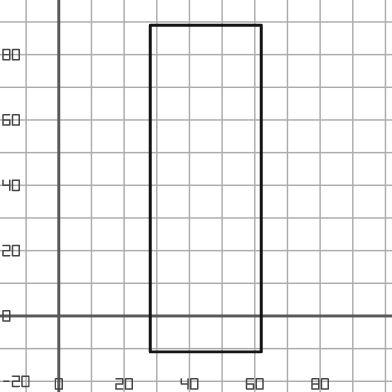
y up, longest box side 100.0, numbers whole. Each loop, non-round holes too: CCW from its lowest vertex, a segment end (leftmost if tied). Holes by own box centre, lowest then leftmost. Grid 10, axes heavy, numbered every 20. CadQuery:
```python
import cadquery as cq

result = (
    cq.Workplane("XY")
    .moveTo(28.0, -11.0)
    .lineTo(62.0, -11.0)
    .lineTo(62.0, 89.0)
    .lineTo(28.0, 89.0)
    .close()
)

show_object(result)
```